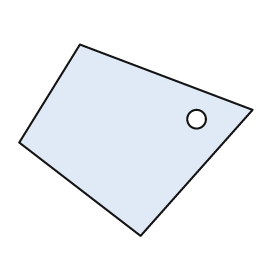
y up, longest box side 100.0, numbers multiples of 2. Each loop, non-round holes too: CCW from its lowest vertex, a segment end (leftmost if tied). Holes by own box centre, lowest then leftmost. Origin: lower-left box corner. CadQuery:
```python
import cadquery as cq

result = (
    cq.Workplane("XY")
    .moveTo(52.0, 0.0)
    .lineTo(100.0, 54.0)
    .lineTo(26.0, 82.0)
    .lineTo(0.0, 40.0)
    .close()
    .moveTo(76.0, 50.0)
    .circle(4.0)
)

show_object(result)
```